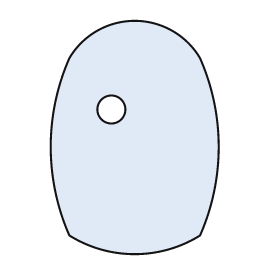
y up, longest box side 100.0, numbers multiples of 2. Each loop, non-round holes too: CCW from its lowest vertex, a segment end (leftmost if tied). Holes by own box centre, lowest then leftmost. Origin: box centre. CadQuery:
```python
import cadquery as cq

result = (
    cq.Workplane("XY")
    .moveTo(-28.0, -42.0)
    .threePointArc((0.0, -50.0), (28.0, -42.0))
    .threePointArc((36.0, -4.0), (28.0, 34.0))
    .threePointArc((0.0, 50.0), (-28.0, 34.0))
    .threePointArc((-36.0, -4.0), (-28.0, -42.0))
    .close()
    .moveTo(-10.0, 12.0)
    .circle(6.0)
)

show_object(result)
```